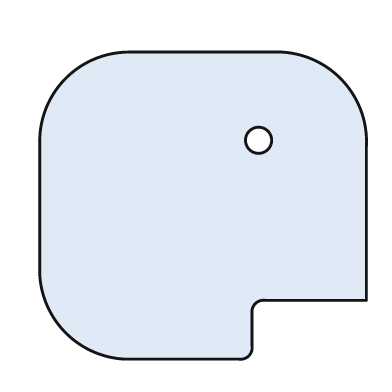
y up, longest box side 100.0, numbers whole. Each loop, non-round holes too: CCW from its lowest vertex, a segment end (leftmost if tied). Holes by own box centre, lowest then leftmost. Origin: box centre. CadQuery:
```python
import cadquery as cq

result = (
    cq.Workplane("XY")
    .moveTo(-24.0, -47.0)
    .lineTo(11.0, -47.0)
    .threePointArc((14.0, -46.0), (15.0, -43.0))
    .lineTo(15.0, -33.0)
    .threePointArc((16.0, -30.0), (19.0, -29.0))
    .lineTo(50.0, -29.0)
    .lineTo(50.0, 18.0)
    .threePointArc((42.0, 39.0), (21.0, 47.0))
    .lineTo(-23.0, 47.0)
    .threePointArc((-42.0, 39.0), (-50.0, 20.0))
    .lineTo(-50.0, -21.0)
    .threePointArc((-42.0, -39.0), (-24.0, -47.0))
    .close()
    .moveTo(17.0, 20.0)
    .circle(4.0)
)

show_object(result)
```